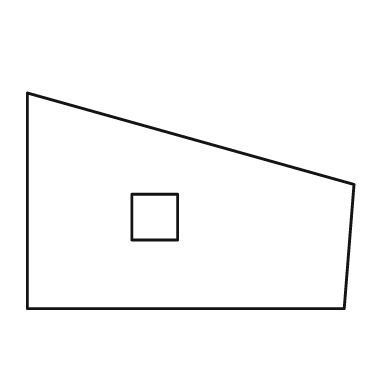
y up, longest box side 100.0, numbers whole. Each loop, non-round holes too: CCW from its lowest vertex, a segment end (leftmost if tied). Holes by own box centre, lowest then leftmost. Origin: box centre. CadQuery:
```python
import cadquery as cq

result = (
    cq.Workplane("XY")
    .moveTo(-50.0, -33.0)
    .lineTo(47.0, -33.0)
    .lineTo(50.0, 5.0)
    .lineTo(-50.0, 33.0)
    .close()
    .moveTo(-18.0, -12.0)
    .lineTo(-4.0, -12.0)
    .lineTo(-4.0, 2.0)
    .lineTo(-18.0, 2.0)
    .close()
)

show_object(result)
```